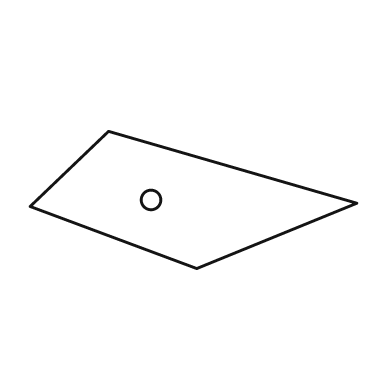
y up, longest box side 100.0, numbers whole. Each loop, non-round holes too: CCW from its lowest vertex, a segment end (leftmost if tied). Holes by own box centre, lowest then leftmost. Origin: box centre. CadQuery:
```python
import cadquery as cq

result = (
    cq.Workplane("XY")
    .moveTo(1.0, -21.0)
    .lineTo(50.0, -1.0)
    .lineTo(-26.0, 21.0)
    .lineTo(-50.0, -2.0)
    .close()
    .moveTo(-13.0, 0.0)
    .circle(3.0)
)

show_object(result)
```